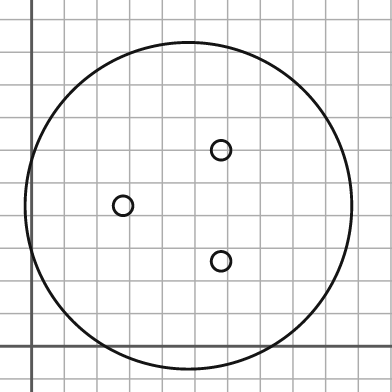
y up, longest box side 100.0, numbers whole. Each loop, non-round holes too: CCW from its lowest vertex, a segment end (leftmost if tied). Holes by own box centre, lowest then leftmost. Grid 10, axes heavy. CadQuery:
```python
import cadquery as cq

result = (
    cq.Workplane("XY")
    .moveTo(48.0, 43.0)
    .circle(50.0)
    .moveTo(58.0, 26.0)
    .circle(3.0)
    .moveTo(28.0, 43.0)
    .circle(3.0)
    .moveTo(58.0, 60.0)
    .circle(3.0)
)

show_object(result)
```